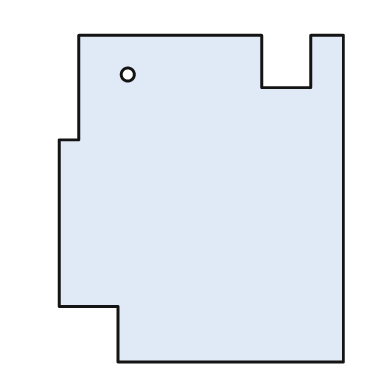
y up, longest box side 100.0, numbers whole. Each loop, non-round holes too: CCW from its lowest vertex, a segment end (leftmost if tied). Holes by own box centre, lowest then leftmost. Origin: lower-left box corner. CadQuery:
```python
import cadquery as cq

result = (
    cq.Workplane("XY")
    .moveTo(18.0, 0.0)
    .lineTo(87.0, 0.0)
    .lineTo(87.0, 100.0)
    .lineTo(77.0, 100.0)
    .lineTo(77.0, 84.0)
    .lineTo(62.0, 84.0)
    .lineTo(62.0, 100.0)
    .lineTo(6.0, 100.0)
    .lineTo(6.0, 68.0)
    .lineTo(0.0, 68.0)
    .lineTo(0.0, 17.0)
    .lineTo(18.0, 17.0)
    .close()
    .moveTo(21.0, 88.0)
    .circle(2.0)
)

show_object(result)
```